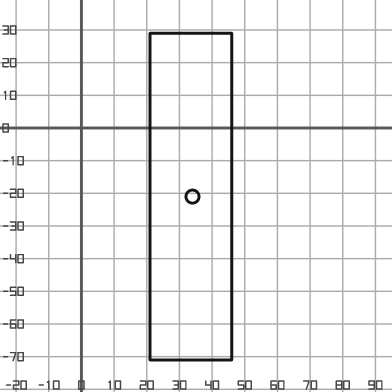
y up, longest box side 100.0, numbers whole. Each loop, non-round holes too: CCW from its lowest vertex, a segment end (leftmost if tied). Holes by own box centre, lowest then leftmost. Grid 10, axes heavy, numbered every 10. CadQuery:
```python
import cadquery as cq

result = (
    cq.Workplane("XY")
    .moveTo(21.0, -71.0)
    .lineTo(46.0, -71.0)
    .lineTo(46.0, 29.0)
    .lineTo(21.0, 29.0)
    .close()
    .moveTo(34.0, -21.0)
    .circle(2.0)
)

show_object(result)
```